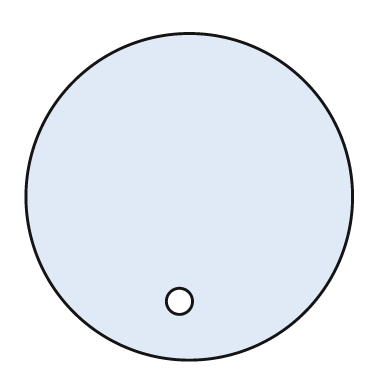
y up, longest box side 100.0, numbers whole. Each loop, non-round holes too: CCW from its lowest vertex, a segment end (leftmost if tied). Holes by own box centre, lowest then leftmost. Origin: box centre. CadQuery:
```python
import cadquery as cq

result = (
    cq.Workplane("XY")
    .moveTo(0.0, 0.0)
    .circle(50.0)
    .moveTo(-3.0, -32.0)
    .circle(4.0)
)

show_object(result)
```